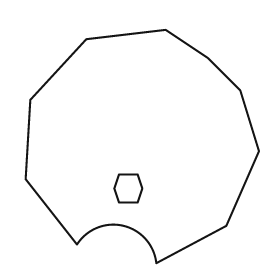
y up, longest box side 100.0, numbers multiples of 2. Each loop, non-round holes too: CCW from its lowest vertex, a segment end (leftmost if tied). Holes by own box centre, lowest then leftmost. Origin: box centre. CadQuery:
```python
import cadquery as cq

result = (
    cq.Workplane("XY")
    .moveTo(6.0, -50.0)
    .lineTo(36.0, -34.0)
    .lineTo(50.0, -2.0)
    .lineTo(42.0, 24.0)
    .lineTo(28.0, 38.0)
    .lineTo(10.0, 50.0)
    .lineTo(-24.0, 46.0)
    .lineTo(-48.0, 20.0)
    .lineTo(-50.0, -14.0)
    .lineTo(-28.0, -42.0)
    .threePointArc((-8.0, -34.0), (6.0, -50.0))
    .close()
    .moveTo(-10.0, -24.0)
    .lineTo(-2.0, -24.0)
    .lineTo(0.0, -18.0)
    .lineTo(-2.0, -12.0)
    .lineTo(-10.0, -12.0)
    .lineTo(-12.0, -18.0)
    .close()
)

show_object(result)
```